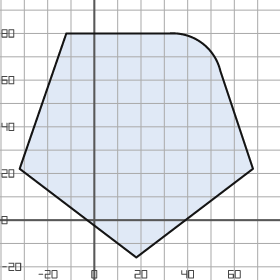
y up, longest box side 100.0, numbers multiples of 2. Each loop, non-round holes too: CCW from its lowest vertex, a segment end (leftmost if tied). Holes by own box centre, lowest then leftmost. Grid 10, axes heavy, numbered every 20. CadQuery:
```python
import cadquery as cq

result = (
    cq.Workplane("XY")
    .moveTo(18.0, -16.0)
    .lineTo(68.0, 22.0)
    .lineTo(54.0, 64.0)
    .threePointArc((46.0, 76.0), (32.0, 80.0))
    .lineTo(-12.0, 80.0)
    .lineTo(-32.0, 22.0)
    .close()
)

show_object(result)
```